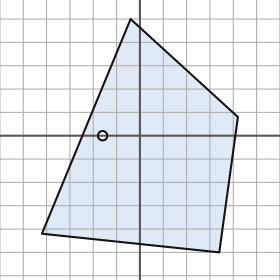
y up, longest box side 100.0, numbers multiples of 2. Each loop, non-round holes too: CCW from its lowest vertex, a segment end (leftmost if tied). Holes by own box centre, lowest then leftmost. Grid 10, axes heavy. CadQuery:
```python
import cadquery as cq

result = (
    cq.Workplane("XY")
    .moveTo(34.0, -50.0)
    .lineTo(42.0, 8.0)
    .lineTo(-4.0, 50.0)
    .lineTo(-42.0, -42.0)
    .close()
    .moveTo(-16.0, 0.0)
    .circle(2.0)
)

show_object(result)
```